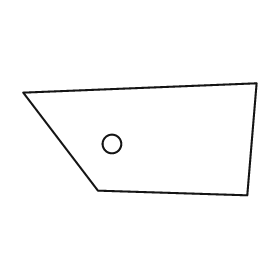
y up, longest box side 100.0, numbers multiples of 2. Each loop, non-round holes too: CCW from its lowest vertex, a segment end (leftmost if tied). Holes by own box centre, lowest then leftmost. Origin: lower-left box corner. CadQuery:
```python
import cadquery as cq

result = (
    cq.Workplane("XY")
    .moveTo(96.0, 0.0)
    .lineTo(100.0, 48.0)
    .lineTo(0.0, 44.0)
    .lineTo(32.0, 2.0)
    .close()
    .moveTo(38.0, 22.0)
    .circle(4.0)
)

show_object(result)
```